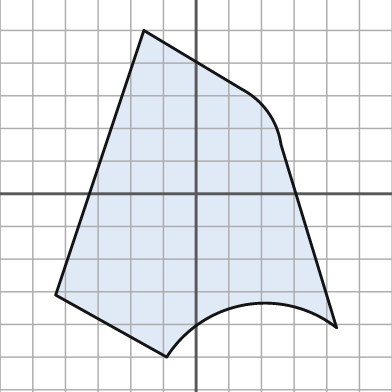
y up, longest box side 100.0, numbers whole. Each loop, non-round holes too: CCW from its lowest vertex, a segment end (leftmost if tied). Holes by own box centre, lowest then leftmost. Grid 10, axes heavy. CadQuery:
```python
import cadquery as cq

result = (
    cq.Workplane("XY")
    .moveTo(-9.0, -50.0)
    .threePointArc((15.0, -34.0), (43.0, -41.0))
    .lineTo(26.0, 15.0)
    .threePointArc((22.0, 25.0), (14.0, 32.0))
    .lineTo(-16.0, 50.0)
    .lineTo(-43.0, -31.0)
    .close()
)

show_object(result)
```